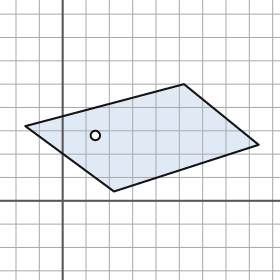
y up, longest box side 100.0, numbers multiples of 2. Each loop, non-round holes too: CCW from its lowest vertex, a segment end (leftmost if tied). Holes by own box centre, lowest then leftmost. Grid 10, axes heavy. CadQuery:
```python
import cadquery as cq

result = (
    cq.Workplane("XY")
    .moveTo(22.0, 4.0)
    .lineTo(84.0, 24.0)
    .lineTo(52.0, 50.0)
    .lineTo(-16.0, 32.0)
    .close()
    .moveTo(14.0, 28.0)
    .circle(2.0)
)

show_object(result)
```